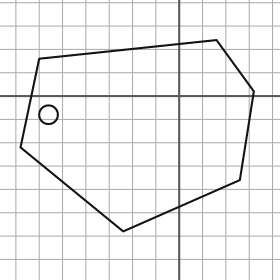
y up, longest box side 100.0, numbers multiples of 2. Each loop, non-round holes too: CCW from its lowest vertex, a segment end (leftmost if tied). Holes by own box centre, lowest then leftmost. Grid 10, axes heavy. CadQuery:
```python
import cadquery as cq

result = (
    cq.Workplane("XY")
    .moveTo(-24.0, -58.0)
    .lineTo(26.0, -36.0)
    .lineTo(32.0, 2.0)
    .lineTo(16.0, 24.0)
    .lineTo(-60.0, 16.0)
    .lineTo(-68.0, -22.0)
    .close()
    .moveTo(-56.0, -8.0)
    .circle(4.0)
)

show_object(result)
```